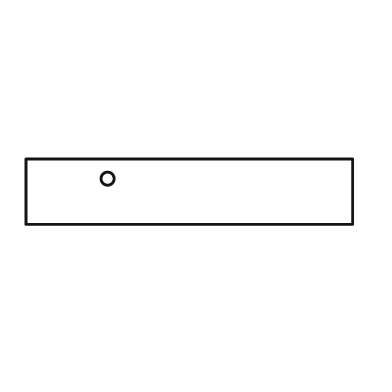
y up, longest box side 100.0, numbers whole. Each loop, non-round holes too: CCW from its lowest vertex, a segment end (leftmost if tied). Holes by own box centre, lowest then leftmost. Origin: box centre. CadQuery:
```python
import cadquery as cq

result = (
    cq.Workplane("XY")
    .moveTo(-50.0, -10.0)
    .lineTo(50.0, -10.0)
    .lineTo(50.0, 10.0)
    .lineTo(-50.0, 10.0)
    .close()
    .moveTo(-25.0, 4.0)
    .circle(2.0)
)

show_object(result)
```